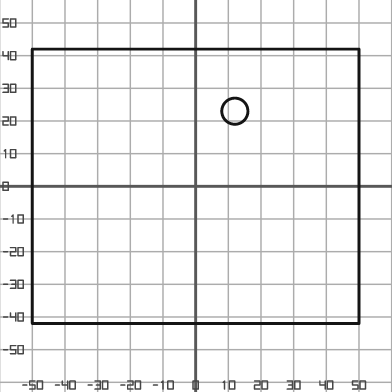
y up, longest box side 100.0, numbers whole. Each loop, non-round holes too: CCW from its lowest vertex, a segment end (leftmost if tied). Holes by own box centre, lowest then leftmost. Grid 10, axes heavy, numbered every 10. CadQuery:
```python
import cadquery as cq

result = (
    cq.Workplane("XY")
    .moveTo(-50.0, -42.0)
    .lineTo(50.0, -42.0)
    .lineTo(50.0, 42.0)
    .lineTo(-50.0, 42.0)
    .close()
    .moveTo(12.0, 23.0)
    .circle(4.0)
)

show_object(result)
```